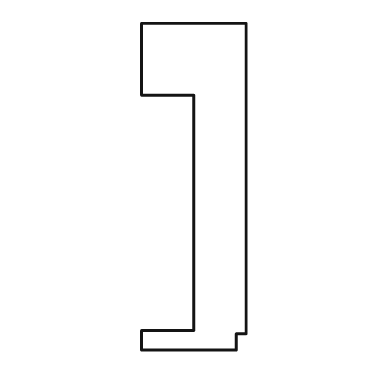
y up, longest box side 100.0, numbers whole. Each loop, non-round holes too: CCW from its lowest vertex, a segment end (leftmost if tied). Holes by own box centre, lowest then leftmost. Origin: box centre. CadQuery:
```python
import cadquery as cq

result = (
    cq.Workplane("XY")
    .moveTo(-16.0, -50.0)
    .lineTo(13.0, -50.0)
    .lineTo(13.0, -45.0)
    .lineTo(16.0, -45.0)
    .lineTo(16.0, 50.0)
    .lineTo(-16.0, 50.0)
    .lineTo(-16.0, 28.0)
    .lineTo(0.0, 28.0)
    .lineTo(0.0, -44.0)
    .lineTo(-16.0, -44.0)
    .close()
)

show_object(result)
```